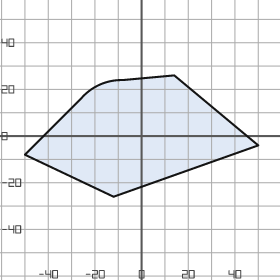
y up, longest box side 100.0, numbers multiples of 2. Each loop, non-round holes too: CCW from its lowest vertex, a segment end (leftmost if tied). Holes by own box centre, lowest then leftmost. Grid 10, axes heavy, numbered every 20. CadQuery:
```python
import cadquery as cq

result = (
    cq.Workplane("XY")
    .moveTo(-12.0, -26.0)
    .lineTo(50.0, -4.0)
    .lineTo(14.0, 26.0)
    .lineTo(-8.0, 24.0)
    .threePointArc((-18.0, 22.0), (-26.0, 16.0))
    .lineTo(-50.0, -8.0)
    .close()
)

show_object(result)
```